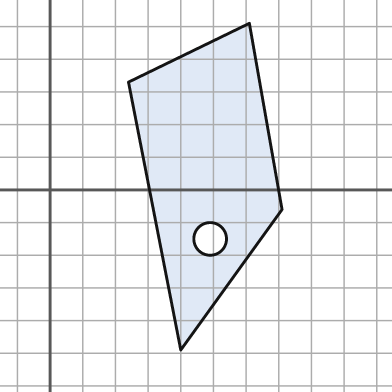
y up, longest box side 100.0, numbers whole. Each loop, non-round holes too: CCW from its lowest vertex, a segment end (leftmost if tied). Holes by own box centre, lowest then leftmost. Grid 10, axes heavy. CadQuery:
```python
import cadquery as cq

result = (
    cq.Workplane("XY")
    .moveTo(40.0, -49.0)
    .lineTo(71.0, -6.0)
    .lineTo(61.0, 51.0)
    .lineTo(24.0, 33.0)
    .close()
    .moveTo(49.0, -15.0)
    .circle(5.0)
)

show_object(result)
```